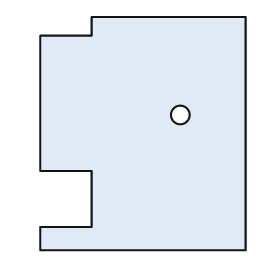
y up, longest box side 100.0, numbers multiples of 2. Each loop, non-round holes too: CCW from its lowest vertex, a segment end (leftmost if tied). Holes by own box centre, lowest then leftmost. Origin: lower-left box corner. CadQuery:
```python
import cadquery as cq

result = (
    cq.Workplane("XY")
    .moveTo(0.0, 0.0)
    .lineTo(88.0, 0.0)
    .lineTo(88.0, 100.0)
    .lineTo(22.0, 100.0)
    .lineTo(22.0, 92.0)
    .lineTo(0.0, 92.0)
    .lineTo(0.0, 34.0)
    .lineTo(22.0, 34.0)
    .lineTo(22.0, 10.0)
    .lineTo(0.0, 10.0)
    .close()
    .moveTo(60.0, 58.0)
    .circle(4.0)
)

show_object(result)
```